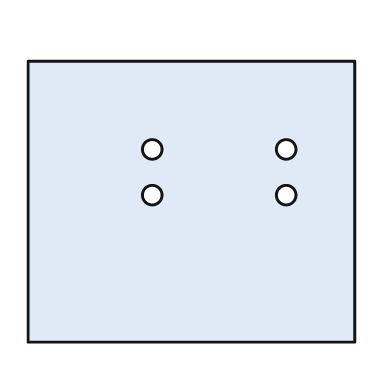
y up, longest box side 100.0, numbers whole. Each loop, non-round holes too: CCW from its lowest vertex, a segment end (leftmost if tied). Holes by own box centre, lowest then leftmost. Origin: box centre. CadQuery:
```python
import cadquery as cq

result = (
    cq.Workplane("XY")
    .moveTo(-50.0, -43.0)
    .lineTo(50.0, -43.0)
    .lineTo(50.0, 43.0)
    .lineTo(-50.0, 43.0)
    .close()
    .moveTo(-12.0, 2.0)
    .circle(3.0)
    .moveTo(29.0, 2.0)
    .circle(3.0)
    .moveTo(-12.0, 16.0)
    .circle(3.0)
    .moveTo(29.0, 16.0)
    .circle(3.0)
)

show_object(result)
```